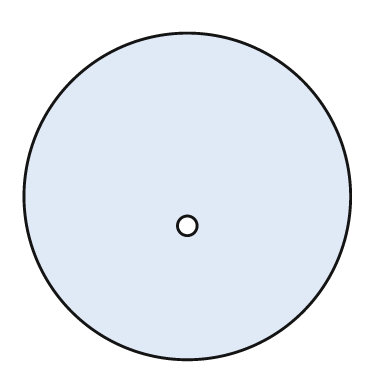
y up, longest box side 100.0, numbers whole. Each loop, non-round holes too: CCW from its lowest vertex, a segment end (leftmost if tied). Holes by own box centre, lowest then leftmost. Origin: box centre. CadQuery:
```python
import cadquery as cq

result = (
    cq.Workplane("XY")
    .moveTo(0.0, 0.0)
    .circle(50.0)
    .moveTo(0.0, -9.0)
    .circle(3.0)
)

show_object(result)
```